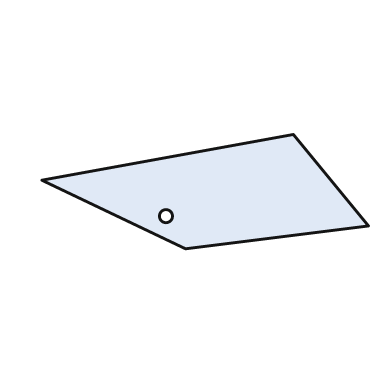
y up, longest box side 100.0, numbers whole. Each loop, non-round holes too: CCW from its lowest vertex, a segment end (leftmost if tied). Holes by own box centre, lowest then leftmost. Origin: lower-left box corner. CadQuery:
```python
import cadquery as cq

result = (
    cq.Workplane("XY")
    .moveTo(44.0, 0.0)
    .lineTo(100.0, 7.0)
    .lineTo(77.0, 35.0)
    .lineTo(0.0, 21.0)
    .close()
    .moveTo(38.0, 10.0)
    .circle(2.0)
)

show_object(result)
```